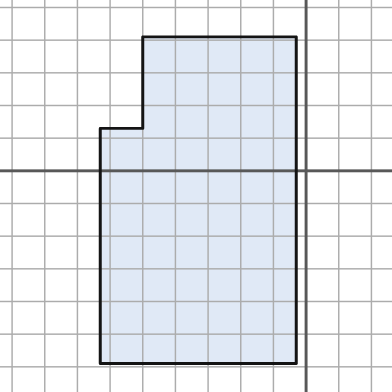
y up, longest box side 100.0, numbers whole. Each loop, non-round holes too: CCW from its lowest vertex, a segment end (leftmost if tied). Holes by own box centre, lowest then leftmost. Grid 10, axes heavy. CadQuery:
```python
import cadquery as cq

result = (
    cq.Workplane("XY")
    .moveTo(-63.0, -59.0)
    .lineTo(-3.0, -59.0)
    .lineTo(-3.0, 41.0)
    .lineTo(-50.0, 41.0)
    .lineTo(-50.0, 13.0)
    .lineTo(-63.0, 13.0)
    .close()
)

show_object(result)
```